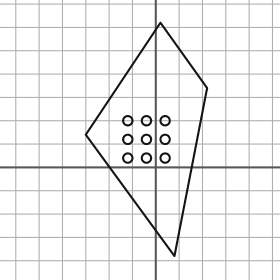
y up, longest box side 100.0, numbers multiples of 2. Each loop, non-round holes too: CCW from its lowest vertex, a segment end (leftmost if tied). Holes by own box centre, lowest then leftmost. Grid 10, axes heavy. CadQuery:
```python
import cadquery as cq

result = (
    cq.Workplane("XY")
    .moveTo(8.0, -38.0)
    .lineTo(22.0, 34.0)
    .lineTo(2.0, 62.0)
    .lineTo(-30.0, 14.0)
    .close()
    .moveTo(-12.0, 4.0)
    .circle(2.0)
    .moveTo(-4.0, 4.0)
    .circle(2.0)
    .moveTo(4.0, 4.0)
    .circle(2.0)
    .moveTo(-12.0, 12.0)
    .circle(2.0)
    .moveTo(-4.0, 12.0)
    .circle(2.0)
    .moveTo(4.0, 12.0)
    .circle(2.0)
    .moveTo(-12.0, 20.0)
    .circle(2.0)
    .moveTo(-4.0, 20.0)
    .circle(2.0)
    .moveTo(4.0, 20.0)
    .circle(2.0)
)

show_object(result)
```